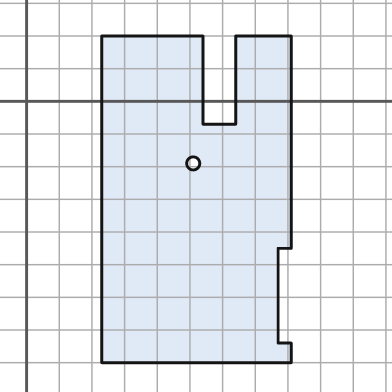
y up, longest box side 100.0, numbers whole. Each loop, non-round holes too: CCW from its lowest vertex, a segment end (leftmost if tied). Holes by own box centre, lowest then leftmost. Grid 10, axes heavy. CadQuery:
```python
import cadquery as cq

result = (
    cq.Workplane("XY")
    .moveTo(23.0, -80.0)
    .lineTo(81.0, -80.0)
    .lineTo(81.0, -74.0)
    .lineTo(77.0, -74.0)
    .lineTo(77.0, -45.0)
    .lineTo(81.0, -45.0)
    .lineTo(81.0, 20.0)
    .lineTo(64.0, 20.0)
    .lineTo(64.0, -7.0)
    .lineTo(54.0, -7.0)
    .lineTo(54.0, 20.0)
    .lineTo(23.0, 20.0)
    .close()
    .moveTo(51.0, -19.0)
    .circle(2.0)
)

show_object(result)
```